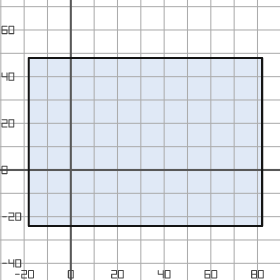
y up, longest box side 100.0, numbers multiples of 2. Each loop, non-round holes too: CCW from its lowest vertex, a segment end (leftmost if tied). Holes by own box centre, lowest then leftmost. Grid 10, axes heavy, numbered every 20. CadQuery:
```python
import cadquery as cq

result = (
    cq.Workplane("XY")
    .moveTo(-18.0, -24.0)
    .lineTo(82.0, -24.0)
    .lineTo(82.0, 48.0)
    .lineTo(-18.0, 48.0)
    .close()
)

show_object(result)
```